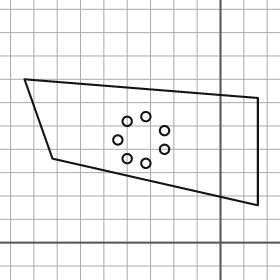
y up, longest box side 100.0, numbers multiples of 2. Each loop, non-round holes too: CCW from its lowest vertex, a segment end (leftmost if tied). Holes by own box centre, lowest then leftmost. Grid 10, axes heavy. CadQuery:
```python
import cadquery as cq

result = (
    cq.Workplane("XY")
    .moveTo(16.0, 16.0)
    .lineTo(16.0, 62.0)
    .lineTo(-84.0, 70.0)
    .lineTo(-72.0, 36.0)
    .close()
    .moveTo(-32.0, 34.0)
    .circle(2.0)
    .moveTo(-40.0, 36.0)
    .circle(2.0)
    .moveTo(-24.0, 40.0)
    .circle(2.0)
    .moveTo(-44.0, 44.0)
    .circle(2.0)
    .moveTo(-24.0, 48.0)
    .circle(2.0)
    .moveTo(-40.0, 52.0)
    .circle(2.0)
    .moveTo(-32.0, 54.0)
    .circle(2.0)
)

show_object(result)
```